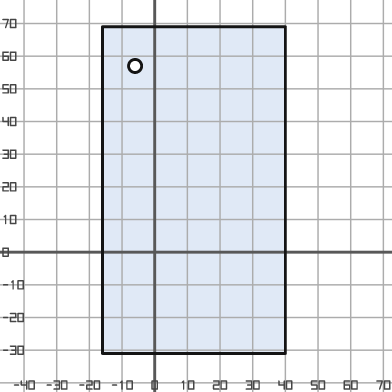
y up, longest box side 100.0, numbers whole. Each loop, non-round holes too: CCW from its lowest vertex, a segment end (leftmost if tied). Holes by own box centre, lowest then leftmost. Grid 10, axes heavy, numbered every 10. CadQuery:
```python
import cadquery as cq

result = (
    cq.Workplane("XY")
    .moveTo(-16.0, -31.0)
    .lineTo(40.0, -31.0)
    .lineTo(40.0, 69.0)
    .lineTo(-16.0, 69.0)
    .close()
    .moveTo(-6.0, 57.0)
    .circle(2.0)
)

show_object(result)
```